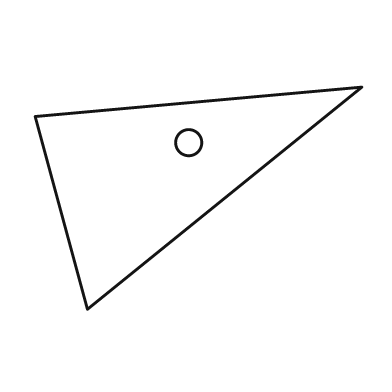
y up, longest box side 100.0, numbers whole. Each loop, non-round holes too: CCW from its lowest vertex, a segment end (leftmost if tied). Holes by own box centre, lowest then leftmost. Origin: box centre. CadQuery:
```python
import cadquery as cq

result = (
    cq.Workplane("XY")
    .moveTo(-34.0, -34.0)
    .lineTo(50.0, 34.0)
    .lineTo(-50.0, 25.0)
    .close()
    .moveTo(-3.0, 17.0)
    .circle(4.0)
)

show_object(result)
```